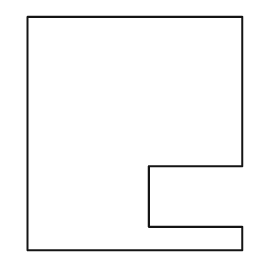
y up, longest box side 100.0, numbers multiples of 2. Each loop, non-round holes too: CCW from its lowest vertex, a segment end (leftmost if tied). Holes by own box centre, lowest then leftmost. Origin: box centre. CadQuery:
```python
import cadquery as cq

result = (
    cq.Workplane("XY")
    .moveTo(-46.0, -50.0)
    .lineTo(46.0, -50.0)
    .lineTo(46.0, -40.0)
    .lineTo(6.0, -40.0)
    .lineTo(6.0, -14.0)
    .lineTo(46.0, -14.0)
    .lineTo(46.0, 50.0)
    .lineTo(-46.0, 50.0)
    .close()
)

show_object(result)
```